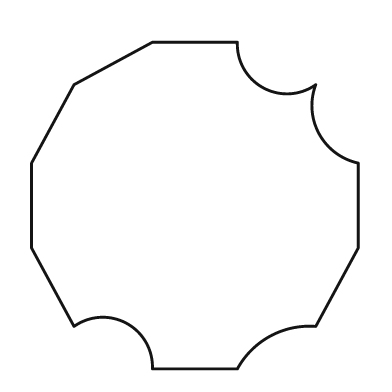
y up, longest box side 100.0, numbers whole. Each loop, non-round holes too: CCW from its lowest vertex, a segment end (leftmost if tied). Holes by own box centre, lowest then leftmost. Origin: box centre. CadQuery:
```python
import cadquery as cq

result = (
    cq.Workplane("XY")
    .moveTo(-13.0, -50.0)
    .lineTo(13.0, -50.0)
    .threePointArc((23.0, -40.0), (37.0, -37.0))
    .lineTo(50.0, -13.0)
    .lineTo(50.0, 13.0)
    .threePointArc((38.0, 22.0), (37.0, 37.0))
    .threePointArc((21.0, 36.0), (13.0, 50.0))
    .lineTo(-13.0, 50.0)
    .lineTo(-37.0, 37.0)
    .lineTo(-50.0, 13.0)
    .lineTo(-50.0, -13.0)
    .lineTo(-37.0, -37.0)
    .threePointArc((-21.0, -36.0), (-13.0, -50.0))
    .close()
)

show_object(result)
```